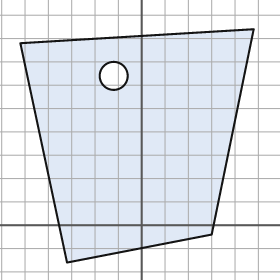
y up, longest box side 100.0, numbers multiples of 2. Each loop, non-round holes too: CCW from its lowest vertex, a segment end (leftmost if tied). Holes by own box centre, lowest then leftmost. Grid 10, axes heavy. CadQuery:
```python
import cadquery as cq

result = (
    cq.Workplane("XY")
    .moveTo(-32.0, -16.0)
    .lineTo(30.0, -4.0)
    .lineTo(48.0, 84.0)
    .lineTo(-52.0, 78.0)
    .close()
    .moveTo(-12.0, 64.0)
    .circle(6.0)
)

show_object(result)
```